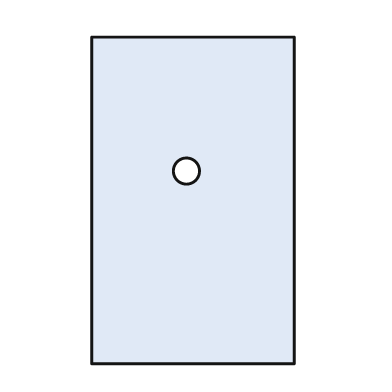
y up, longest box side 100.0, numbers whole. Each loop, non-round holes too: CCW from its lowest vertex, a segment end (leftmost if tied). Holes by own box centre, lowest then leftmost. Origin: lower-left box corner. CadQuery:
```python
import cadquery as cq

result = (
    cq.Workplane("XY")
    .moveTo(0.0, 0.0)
    .lineTo(62.0, 0.0)
    .lineTo(62.0, 100.0)
    .lineTo(0.0, 100.0)
    .close()
    .moveTo(29.0, 59.0)
    .circle(4.0)
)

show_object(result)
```